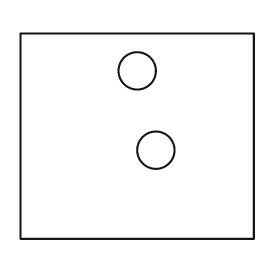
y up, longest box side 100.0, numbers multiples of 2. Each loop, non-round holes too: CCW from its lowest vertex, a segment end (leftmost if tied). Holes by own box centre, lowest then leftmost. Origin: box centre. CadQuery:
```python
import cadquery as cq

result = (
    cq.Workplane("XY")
    .moveTo(-50.0, -44.0)
    .lineTo(50.0, -44.0)
    .lineTo(50.0, 44.0)
    .lineTo(-50.0, 44.0)
    .close()
    .moveTo(8.0, -6.0)
    .circle(8.0)
    .moveTo(0.0, 28.0)
    .circle(8.0)
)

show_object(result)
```